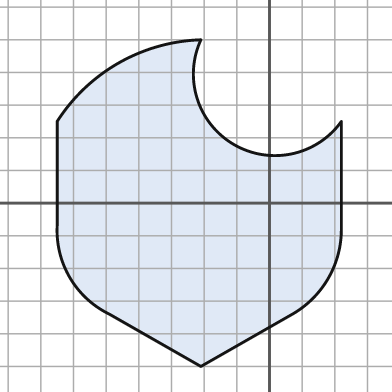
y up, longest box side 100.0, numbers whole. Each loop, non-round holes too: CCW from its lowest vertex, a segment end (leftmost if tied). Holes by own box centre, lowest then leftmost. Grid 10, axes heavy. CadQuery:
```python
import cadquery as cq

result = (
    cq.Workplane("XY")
    .moveTo(-21.0, -50.0)
    .lineTo(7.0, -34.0)
    .threePointArc((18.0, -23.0), (22.0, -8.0))
    .lineTo(22.0, 25.0)
    .threePointArc((-11.0, 18.0), (-21.0, 50.0))
    .threePointArc((-46.0, 43.0), (-65.0, 25.0))
    .lineTo(-65.0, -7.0)
    .threePointArc((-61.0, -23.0), (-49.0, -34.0))
    .close()
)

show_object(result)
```